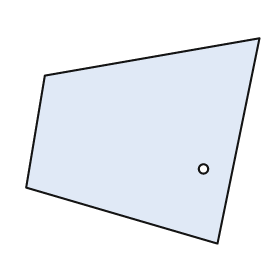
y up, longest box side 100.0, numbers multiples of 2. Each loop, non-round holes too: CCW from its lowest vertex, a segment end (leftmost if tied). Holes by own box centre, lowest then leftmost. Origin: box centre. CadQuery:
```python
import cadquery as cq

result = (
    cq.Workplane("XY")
    .moveTo(32.0, -44.0)
    .lineTo(50.0, 44.0)
    .lineTo(-42.0, 28.0)
    .lineTo(-50.0, -20.0)
    .close()
    .moveTo(26.0, -12.0)
    .circle(2.0)
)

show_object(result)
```